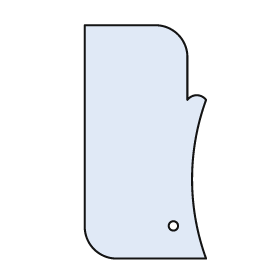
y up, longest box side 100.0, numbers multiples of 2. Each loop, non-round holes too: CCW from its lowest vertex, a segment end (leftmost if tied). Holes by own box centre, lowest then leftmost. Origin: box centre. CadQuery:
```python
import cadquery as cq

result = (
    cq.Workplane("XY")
    .moveTo(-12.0, -50.0)
    .lineTo(26.0, -50.0)
    .threePointArc((20.0, -16.0), (26.0, 18.0))
    .threePointArc((22.0, 20.0), (18.0, 18.0))
    .lineTo(18.0, 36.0)
    .threePointArc((14.0, 46.0), (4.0, 50.0))
    .lineTo(-26.0, 50.0)
    .lineTo(-26.0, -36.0)
    .threePointArc((-22.0, -46.0), (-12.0, -50.0))
    .close()
    .moveTo(12.0, -36.0)
    .circle(2.0)
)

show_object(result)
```